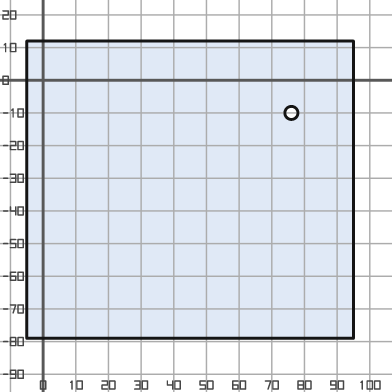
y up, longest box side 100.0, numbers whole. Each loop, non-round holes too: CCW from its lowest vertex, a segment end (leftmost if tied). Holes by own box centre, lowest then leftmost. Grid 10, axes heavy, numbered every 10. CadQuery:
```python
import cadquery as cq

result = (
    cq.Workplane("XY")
    .moveTo(-5.0, -79.0)
    .lineTo(95.0, -79.0)
    .lineTo(95.0, 12.0)
    .lineTo(-5.0, 12.0)
    .close()
    .moveTo(76.0, -10.0)
    .circle(2.0)
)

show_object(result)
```